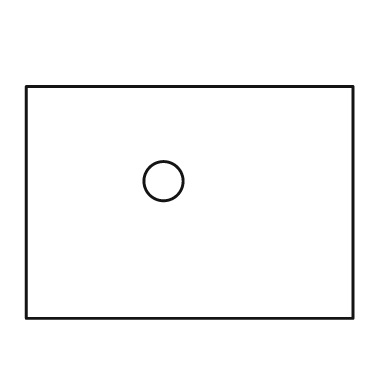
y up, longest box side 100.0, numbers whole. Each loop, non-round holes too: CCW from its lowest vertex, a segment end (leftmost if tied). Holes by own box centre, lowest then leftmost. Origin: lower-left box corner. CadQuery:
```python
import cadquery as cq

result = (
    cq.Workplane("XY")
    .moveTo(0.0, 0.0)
    .lineTo(100.0, 0.0)
    .lineTo(100.0, 71.0)
    .lineTo(0.0, 71.0)
    .close()
    .moveTo(42.0, 42.0)
    .circle(6.0)
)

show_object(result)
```